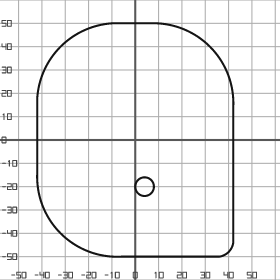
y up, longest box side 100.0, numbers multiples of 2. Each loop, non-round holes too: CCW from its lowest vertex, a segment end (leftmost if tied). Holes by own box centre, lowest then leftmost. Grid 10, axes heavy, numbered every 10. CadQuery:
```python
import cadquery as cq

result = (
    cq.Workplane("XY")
    .moveTo(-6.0, -50.0)
    .lineTo(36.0, -50.0)
    .threePointArc((40.0, -48.0), (42.0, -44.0))
    .lineTo(42.0, 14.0)
    .threePointArc((32.0, 40.0), (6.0, 50.0))
    .lineTo(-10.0, 50.0)
    .threePointArc((-32.0, 40.0), (-42.0, 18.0))
    .lineTo(-42.0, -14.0)
    .threePointArc((-32.0, -40.0), (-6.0, -50.0))
    .close()
    .moveTo(4.0, -20.0)
    .circle(4.0)
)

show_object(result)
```